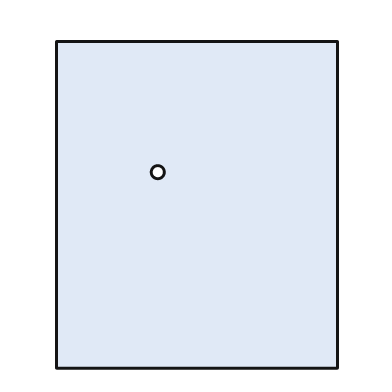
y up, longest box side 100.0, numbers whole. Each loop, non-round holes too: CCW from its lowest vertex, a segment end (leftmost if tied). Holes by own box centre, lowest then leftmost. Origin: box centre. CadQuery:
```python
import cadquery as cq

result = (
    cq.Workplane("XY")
    .moveTo(-43.0, -50.0)
    .lineTo(43.0, -50.0)
    .lineTo(43.0, 50.0)
    .lineTo(-43.0, 50.0)
    .close()
    .moveTo(-12.0, 10.0)
    .circle(2.0)
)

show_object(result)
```